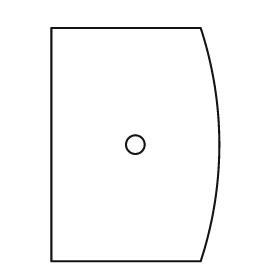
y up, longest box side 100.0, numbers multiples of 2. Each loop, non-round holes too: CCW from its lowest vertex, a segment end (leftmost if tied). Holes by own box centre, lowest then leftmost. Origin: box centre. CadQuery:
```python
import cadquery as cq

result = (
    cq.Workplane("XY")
    .moveTo(-36.0, -50.0)
    .lineTo(28.0, -50.0)
    .threePointArc((36.0, 0.0), (28.0, 50.0))
    .lineTo(-36.0, 50.0)
    .close()
    .moveTo(0.0, 0.0)
    .circle(4.0)
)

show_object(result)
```